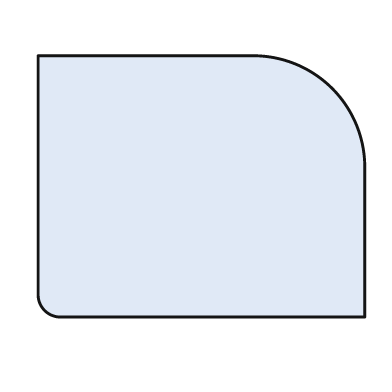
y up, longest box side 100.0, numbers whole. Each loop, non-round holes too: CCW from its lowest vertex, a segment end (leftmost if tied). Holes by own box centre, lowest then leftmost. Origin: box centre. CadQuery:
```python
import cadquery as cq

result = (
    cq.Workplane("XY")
    .moveTo(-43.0, -40.0)
    .lineTo(50.0, -40.0)
    .lineTo(50.0, 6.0)
    .threePointArc((40.0, 30.0), (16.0, 40.0))
    .lineTo(-50.0, 40.0)
    .lineTo(-50.0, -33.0)
    .threePointArc((-48.0, -38.0), (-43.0, -40.0))
    .close()
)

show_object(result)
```